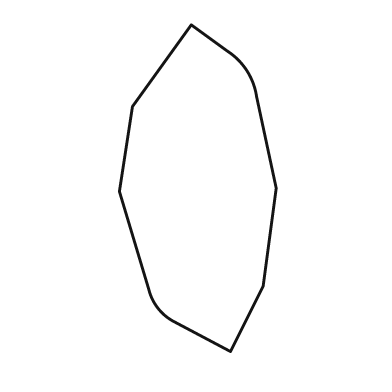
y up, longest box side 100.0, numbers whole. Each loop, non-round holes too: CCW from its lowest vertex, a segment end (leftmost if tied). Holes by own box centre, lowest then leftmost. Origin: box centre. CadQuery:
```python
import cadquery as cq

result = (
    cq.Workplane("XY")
    .moveTo(10.0, -50.0)
    .lineTo(20.0, -30.0)
    .lineTo(24.0, 0.0)
    .lineTo(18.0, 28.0)
    .threePointArc((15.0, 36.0), (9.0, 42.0))
    .lineTo(-2.0, 50.0)
    .lineTo(-20.0, 25.0)
    .lineTo(-24.0, -1.0)
    .lineTo(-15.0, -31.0)
    .threePointArc((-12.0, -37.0), (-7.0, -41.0))
    .close()
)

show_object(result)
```